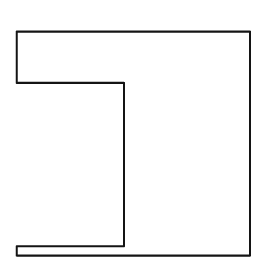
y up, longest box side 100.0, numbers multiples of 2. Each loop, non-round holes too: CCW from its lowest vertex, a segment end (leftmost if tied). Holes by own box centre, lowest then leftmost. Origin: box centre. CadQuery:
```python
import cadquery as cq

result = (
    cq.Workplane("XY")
    .moveTo(-50.0, -48.0)
    .lineTo(50.0, -48.0)
    .lineTo(50.0, 48.0)
    .lineTo(-50.0, 48.0)
    .lineTo(-50.0, 26.0)
    .lineTo(-4.0, 26.0)
    .lineTo(-4.0, -44.0)
    .lineTo(-50.0, -44.0)
    .close()
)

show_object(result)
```